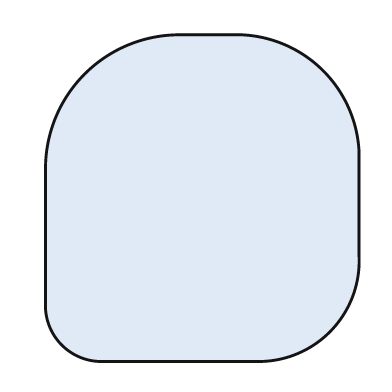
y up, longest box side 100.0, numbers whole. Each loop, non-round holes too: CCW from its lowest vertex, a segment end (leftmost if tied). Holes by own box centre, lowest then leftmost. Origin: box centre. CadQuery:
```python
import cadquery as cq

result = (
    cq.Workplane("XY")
    .moveTo(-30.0, -50.0)
    .lineTo(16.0, -50.0)
    .threePointArc((39.0, -41.0), (48.0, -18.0))
    .lineTo(48.0, 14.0)
    .threePointArc((37.0, 39.0), (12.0, 50.0))
    .lineTo(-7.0, 50.0)
    .threePointArc((-36.0, 38.0), (-48.0, 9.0))
    .lineTo(-48.0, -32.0)
    .threePointArc((-43.0, -45.0), (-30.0, -50.0))
    .close()
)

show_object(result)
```